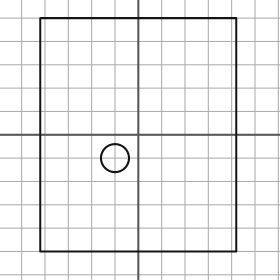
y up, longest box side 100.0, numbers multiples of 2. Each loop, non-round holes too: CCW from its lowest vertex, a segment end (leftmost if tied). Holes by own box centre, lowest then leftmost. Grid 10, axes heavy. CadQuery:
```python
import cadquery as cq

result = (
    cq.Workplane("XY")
    .moveTo(-42.0, -50.0)
    .lineTo(42.0, -50.0)
    .lineTo(42.0, 50.0)
    .lineTo(-42.0, 50.0)
    .close()
    .moveTo(-10.0, -10.0)
    .circle(6.0)
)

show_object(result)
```